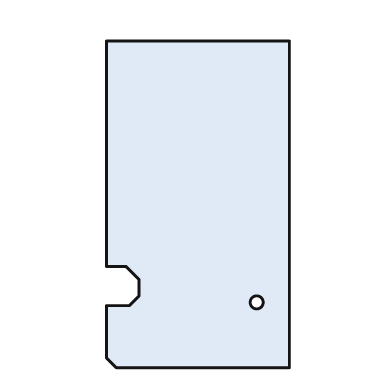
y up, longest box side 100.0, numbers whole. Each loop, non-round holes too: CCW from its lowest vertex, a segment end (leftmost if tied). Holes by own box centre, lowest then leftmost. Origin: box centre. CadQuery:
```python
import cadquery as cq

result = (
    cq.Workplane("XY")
    .moveTo(-25.0, -50.0)
    .lineTo(28.0, -50.0)
    .lineTo(28.0, 50.0)
    .lineTo(-28.0, 50.0)
    .lineTo(-28.0, -19.0)
    .lineTo(-22.0, -19.0)
    .lineTo(-18.0, -23.0)
    .lineTo(-18.0, -28.0)
    .lineTo(-21.0, -31.0)
    .lineTo(-28.0, -31.0)
    .lineTo(-28.0, -47.0)
    .close()
    .moveTo(18.0, -30.0)
    .circle(2.0)
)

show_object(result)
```